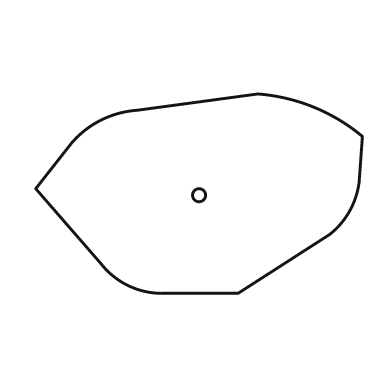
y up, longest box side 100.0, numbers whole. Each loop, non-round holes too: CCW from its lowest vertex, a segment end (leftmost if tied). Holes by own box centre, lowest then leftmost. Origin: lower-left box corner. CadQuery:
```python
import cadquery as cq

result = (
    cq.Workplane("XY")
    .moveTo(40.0, 0.0)
    .lineTo(62.0, 0.0)
    .lineTo(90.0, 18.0)
    .threePointArc((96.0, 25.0), (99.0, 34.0))
    .lineTo(100.0, 48.0)
    .threePointArc((85.0, 57.0), (68.0, 61.0))
    .lineTo(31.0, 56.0)
    .threePointArc((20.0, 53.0), (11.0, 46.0))
    .lineTo(0.0, 32.0)
    .lineTo(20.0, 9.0)
    .threePointArc((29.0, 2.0), (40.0, 0.0))
    .close()
    .moveTo(50.0, 30.0)
    .circle(2.0)
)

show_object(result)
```